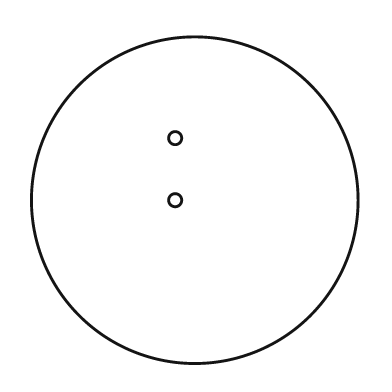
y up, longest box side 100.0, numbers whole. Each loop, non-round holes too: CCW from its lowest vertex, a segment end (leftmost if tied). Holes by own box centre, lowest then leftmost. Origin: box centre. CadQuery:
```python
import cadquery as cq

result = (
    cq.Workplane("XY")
    .moveTo(0.0, 0.0)
    .circle(50.0)
    .moveTo(-6.0, 0.0)
    .circle(2.0)
    .moveTo(-6.0, 19.0)
    .circle(2.0)
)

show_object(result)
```